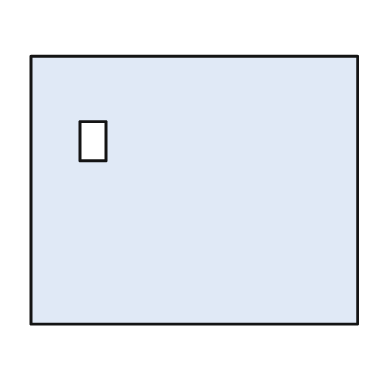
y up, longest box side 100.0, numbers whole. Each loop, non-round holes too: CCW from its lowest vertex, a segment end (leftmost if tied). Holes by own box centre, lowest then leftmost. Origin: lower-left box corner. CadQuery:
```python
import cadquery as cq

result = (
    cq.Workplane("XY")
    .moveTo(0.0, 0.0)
    .lineTo(100.0, 0.0)
    .lineTo(100.0, 82.0)
    .lineTo(0.0, 82.0)
    .close()
    .moveTo(15.0, 50.0)
    .lineTo(23.0, 50.0)
    .lineTo(23.0, 62.0)
    .lineTo(15.0, 62.0)
    .close()
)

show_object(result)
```